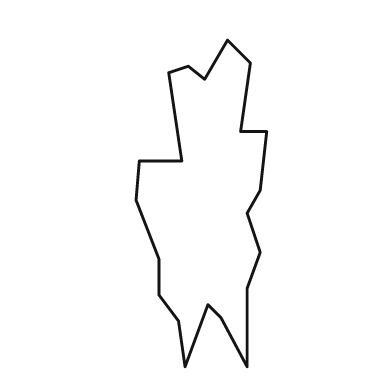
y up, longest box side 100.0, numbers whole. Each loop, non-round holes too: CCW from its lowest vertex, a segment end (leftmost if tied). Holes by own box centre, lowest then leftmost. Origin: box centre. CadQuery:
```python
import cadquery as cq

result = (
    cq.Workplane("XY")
    .moveTo(-5.0, -50.0)
    .lineTo(2.0, -31.0)
    .lineTo(6.0, -35.0)
    .lineTo(14.0, -50.0)
    .lineTo(14.0, -26.0)
    .lineTo(18.0, -15.0)
    .lineTo(14.0, -3.0)
    .lineTo(18.0, 4.0)
    .lineTo(20.0, 22.0)
    .lineTo(12.0, 22.0)
    .lineTo(15.0, 43.0)
    .lineTo(8.0, 50.0)
    .lineTo(1.0, 38.0)
    .lineTo(-4.0, 42.0)
    .lineTo(-10.0, 40.0)
    .lineTo(-6.0, 13.0)
    .lineTo(-19.0, 13.0)
    .lineTo(-20.0, 1.0)
    .lineTo(-13.0, -17.0)
    .lineTo(-13.0, -28.0)
    .lineTo(-7.0, -36.0)
    .close()
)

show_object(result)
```